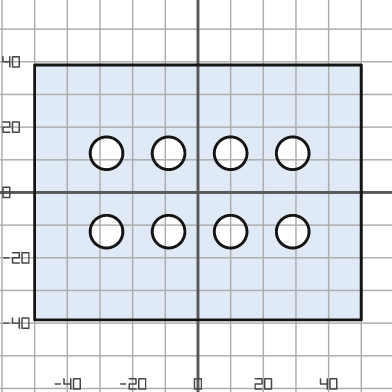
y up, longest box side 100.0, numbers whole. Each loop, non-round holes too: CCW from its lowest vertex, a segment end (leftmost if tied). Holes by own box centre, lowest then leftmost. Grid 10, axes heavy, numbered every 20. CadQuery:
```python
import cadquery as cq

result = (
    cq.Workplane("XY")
    .moveTo(-50.0, -39.0)
    .lineTo(50.0, -39.0)
    .lineTo(50.0, 39.0)
    .lineTo(-50.0, 39.0)
    .close()
    .moveTo(-28.0, -12.0)
    .circle(5.0)
    .moveTo(-9.0, -12.0)
    .circle(5.0)
    .moveTo(10.0, -12.0)
    .circle(5.0)
    .moveTo(29.0, -12.0)
    .circle(5.0)
    .moveTo(-28.0, 12.0)
    .circle(5.0)
    .moveTo(-9.0, 12.0)
    .circle(5.0)
    .moveTo(10.0, 12.0)
    .circle(5.0)
    .moveTo(29.0, 12.0)
    .circle(5.0)
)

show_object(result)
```